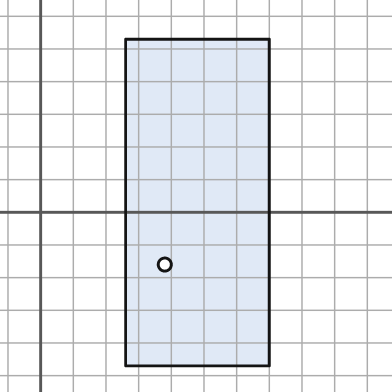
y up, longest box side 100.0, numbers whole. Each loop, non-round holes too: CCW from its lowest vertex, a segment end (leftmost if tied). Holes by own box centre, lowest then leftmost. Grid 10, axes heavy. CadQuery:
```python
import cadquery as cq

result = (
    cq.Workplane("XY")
    .moveTo(26.0, -47.0)
    .lineTo(70.0, -47.0)
    .lineTo(70.0, 53.0)
    .lineTo(26.0, 53.0)
    .close()
    .moveTo(38.0, -16.0)
    .circle(2.0)
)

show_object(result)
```